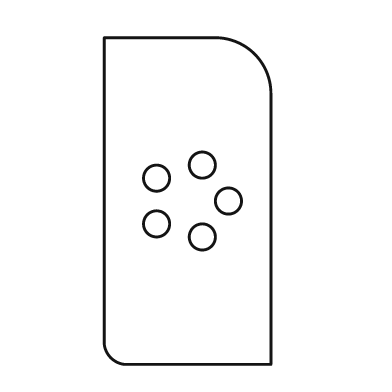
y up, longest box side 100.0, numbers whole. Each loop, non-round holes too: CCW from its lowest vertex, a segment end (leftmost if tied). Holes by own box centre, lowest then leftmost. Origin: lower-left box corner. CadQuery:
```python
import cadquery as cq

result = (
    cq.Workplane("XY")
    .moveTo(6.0, 0.0)
    .lineTo(51.0, 0.0)
    .lineTo(51.0, 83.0)
    .threePointArc((46.0, 95.0), (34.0, 100.0))
    .lineTo(0.0, 100.0)
    .lineTo(0.0, 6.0)
    .threePointArc((2.0, 2.0), (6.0, 0.0))
    .close()
    .moveTo(30.0, 39.0)
    .circle(4.0)
    .moveTo(16.0, 43.0)
    .circle(4.0)
    .moveTo(38.0, 50.0)
    .circle(4.0)
    .moveTo(16.0, 57.0)
    .circle(4.0)
    .moveTo(30.0, 61.0)
    .circle(4.0)
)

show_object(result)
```